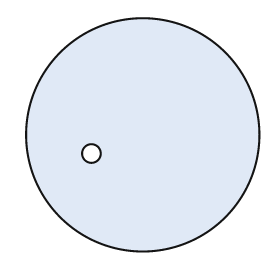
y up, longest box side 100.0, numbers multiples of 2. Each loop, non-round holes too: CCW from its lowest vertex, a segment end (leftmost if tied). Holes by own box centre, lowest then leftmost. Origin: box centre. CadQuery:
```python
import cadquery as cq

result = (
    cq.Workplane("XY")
    .moveTo(0.0, 0.0)
    .circle(50.0)
    .moveTo(-22.0, -8.0)
    .circle(4.0)
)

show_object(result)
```